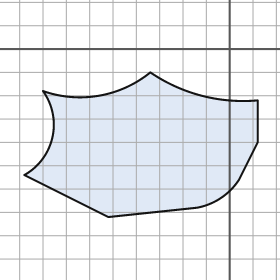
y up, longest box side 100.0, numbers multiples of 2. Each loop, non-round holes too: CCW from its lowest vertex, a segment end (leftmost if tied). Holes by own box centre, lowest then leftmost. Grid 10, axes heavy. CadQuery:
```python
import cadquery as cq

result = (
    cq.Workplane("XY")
    .moveTo(-52.0, -72.0)
    .lineTo(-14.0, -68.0)
    .threePointArc((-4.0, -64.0), (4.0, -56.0))
    .lineTo(12.0, -40.0)
    .lineTo(12.0, -22.0)
    .threePointArc((-12.0, -20.0), (-34.0, -10.0))
    .threePointArc((-56.0, -20.0), (-80.0, -18.0))
    .threePointArc((-76.0, -38.0), (-88.0, -54.0))
    .close()
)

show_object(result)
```